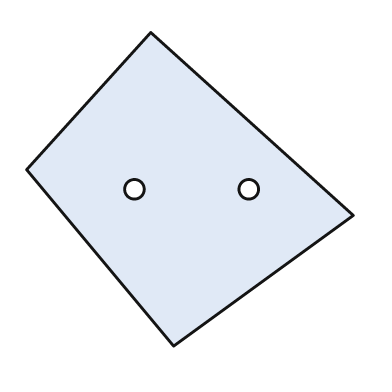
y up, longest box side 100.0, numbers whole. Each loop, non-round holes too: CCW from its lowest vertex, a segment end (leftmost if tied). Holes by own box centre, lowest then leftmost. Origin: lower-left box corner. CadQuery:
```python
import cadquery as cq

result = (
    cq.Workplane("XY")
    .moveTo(45.0, 0.0)
    .lineTo(100.0, 40.0)
    .lineTo(38.0, 96.0)
    .lineTo(0.0, 54.0)
    .close()
    .moveTo(33.0, 48.0)
    .circle(3.0)
    .moveTo(68.0, 48.0)
    .circle(3.0)
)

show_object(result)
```